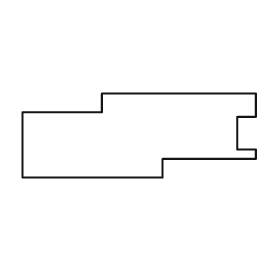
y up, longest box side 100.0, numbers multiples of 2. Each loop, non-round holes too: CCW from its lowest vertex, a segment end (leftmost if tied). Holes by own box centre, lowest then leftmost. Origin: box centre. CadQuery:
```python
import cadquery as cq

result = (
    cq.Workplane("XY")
    .moveTo(-50.0, -18.0)
    .lineTo(10.0, -18.0)
    .lineTo(10.0, -10.0)
    .lineTo(50.0, -10.0)
    .lineTo(50.0, -6.0)
    .lineTo(42.0, -6.0)
    .lineTo(42.0, 8.0)
    .lineTo(50.0, 8.0)
    .lineTo(50.0, 18.0)
    .lineTo(-16.0, 18.0)
    .lineTo(-16.0, 10.0)
    .lineTo(-50.0, 10.0)
    .close()
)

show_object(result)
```